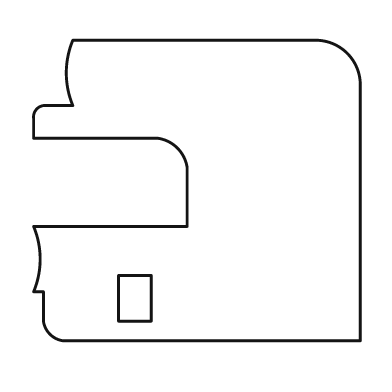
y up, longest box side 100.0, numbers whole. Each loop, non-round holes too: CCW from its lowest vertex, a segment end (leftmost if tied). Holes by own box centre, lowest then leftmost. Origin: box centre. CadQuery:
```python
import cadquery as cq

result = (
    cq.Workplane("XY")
    .moveTo(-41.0, -46.0)
    .lineTo(50.0, -46.0)
    .lineTo(50.0, 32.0)
    .threePointArc((46.0, 42.0), (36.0, 46.0))
    .lineTo(-38.0, 46.0)
    .threePointArc((-40.0, 36.0), (-38.0, 26.0))
    .lineTo(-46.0, 26.0)
    .threePointArc((-49.0, 25.0), (-50.0, 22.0))
    .lineTo(-50.0, 16.0)
    .lineTo(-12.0, 16.0)
    .threePointArc((-6.0, 13.0), (-3.0, 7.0))
    .lineTo(-3.0, -11.0)
    .lineTo(-50.0, -11.0)
    .threePointArc((-48.0, -21.0), (-50.0, -31.0))
    .lineTo(-47.0, -31.0)
    .lineTo(-47.0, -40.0)
    .threePointArc((-45.0, -44.0), (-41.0, -46.0))
    .close()
    .moveTo(-24.0, -40.0)
    .lineTo(-14.0, -40.0)
    .lineTo(-14.0, -26.0)
    .lineTo(-24.0, -26.0)
    .close()
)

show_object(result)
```